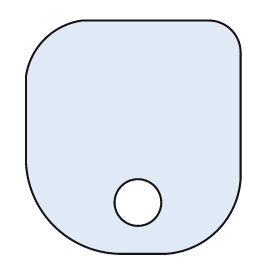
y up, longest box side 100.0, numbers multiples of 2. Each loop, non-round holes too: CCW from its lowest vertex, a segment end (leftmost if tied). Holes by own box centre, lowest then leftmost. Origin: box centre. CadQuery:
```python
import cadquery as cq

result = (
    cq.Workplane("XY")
    .moveTo(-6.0, -50.0)
    .lineTo(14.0, -50.0)
    .threePointArc((36.0, -40.0), (46.0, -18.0))
    .lineTo(46.0, 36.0)
    .threePointArc((42.0, 46.0), (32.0, 50.0))
    .lineTo(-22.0, 50.0)
    .threePointArc((-38.0, 42.0), (-46.0, 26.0))
    .lineTo(-46.0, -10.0)
    .threePointArc((-34.0, -38.0), (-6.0, -50.0))
    .close()
    .moveTo(2.0, -28.0)
    .circle(10.0)
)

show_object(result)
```